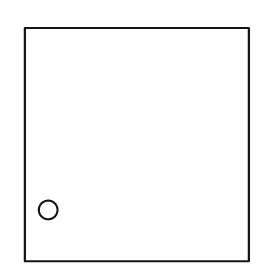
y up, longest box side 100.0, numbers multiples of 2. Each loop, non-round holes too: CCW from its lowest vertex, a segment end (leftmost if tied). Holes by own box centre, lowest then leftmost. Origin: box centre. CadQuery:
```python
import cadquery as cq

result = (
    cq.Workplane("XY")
    .moveTo(-48.0, -50.0)
    .lineTo(48.0, -50.0)
    .lineTo(48.0, 50.0)
    .lineTo(-48.0, 50.0)
    .close()
    .moveTo(-38.0, -28.0)
    .circle(4.0)
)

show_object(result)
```